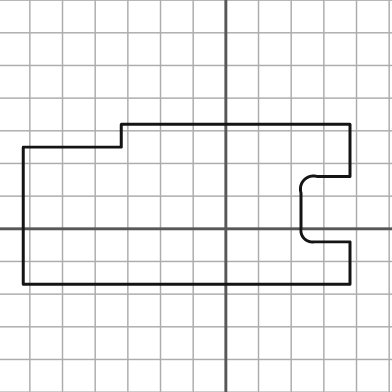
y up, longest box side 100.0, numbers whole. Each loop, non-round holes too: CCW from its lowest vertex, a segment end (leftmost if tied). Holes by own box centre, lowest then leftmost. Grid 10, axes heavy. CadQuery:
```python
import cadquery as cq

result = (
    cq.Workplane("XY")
    .moveTo(-62.0, -17.0)
    .lineTo(38.0, -17.0)
    .lineTo(38.0, -4.0)
    .lineTo(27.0, -4.0)
    .threePointArc((24.0, -3.0), (23.0, 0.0))
    .lineTo(23.0, 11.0)
    .threePointArc((24.0, 15.0), (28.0, 16.0))
    .lineTo(38.0, 16.0)
    .lineTo(38.0, 32.0)
    .lineTo(-32.0, 32.0)
    .lineTo(-32.0, 25.0)
    .lineTo(-62.0, 25.0)
    .close()
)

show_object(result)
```